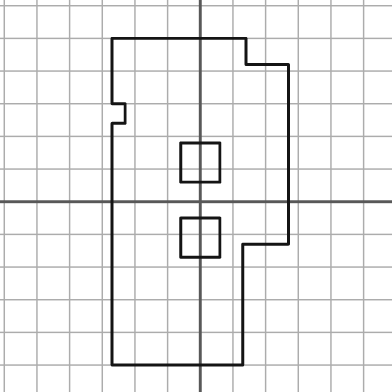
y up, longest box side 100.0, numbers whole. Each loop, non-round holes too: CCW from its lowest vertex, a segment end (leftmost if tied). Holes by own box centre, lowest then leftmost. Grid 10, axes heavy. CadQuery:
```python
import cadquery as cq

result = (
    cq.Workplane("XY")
    .moveTo(-27.0, -50.0)
    .lineTo(13.0, -50.0)
    .lineTo(13.0, -13.0)
    .lineTo(27.0, -13.0)
    .lineTo(27.0, 42.0)
    .lineTo(14.0, 42.0)
    .lineTo(14.0, 50.0)
    .lineTo(-27.0, 50.0)
    .lineTo(-27.0, 30.0)
    .lineTo(-23.0, 30.0)
    .lineTo(-23.0, 24.0)
    .lineTo(-27.0, 24.0)
    .close()
    .moveTo(-6.0, -17.0)
    .lineTo(6.0, -17.0)
    .lineTo(6.0, -5.0)
    .lineTo(-6.0, -5.0)
    .close()
    .moveTo(-6.0, 6.0)
    .lineTo(6.0, 6.0)
    .lineTo(6.0, 18.0)
    .lineTo(-6.0, 18.0)
    .close()
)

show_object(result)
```